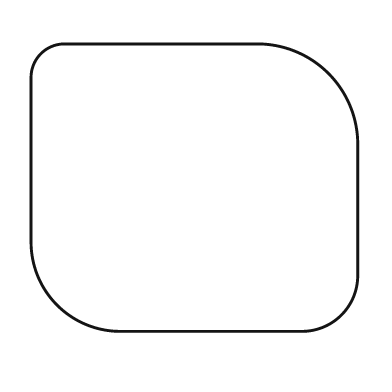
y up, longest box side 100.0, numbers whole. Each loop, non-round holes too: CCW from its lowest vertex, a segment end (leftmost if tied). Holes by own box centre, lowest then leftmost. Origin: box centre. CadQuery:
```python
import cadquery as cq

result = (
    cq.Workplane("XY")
    .moveTo(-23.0, -44.0)
    .lineTo(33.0, -44.0)
    .threePointArc((45.0, -39.0), (50.0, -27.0))
    .lineTo(50.0, 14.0)
    .threePointArc((41.0, 35.0), (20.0, 44.0))
    .lineTo(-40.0, 44.0)
    .threePointArc((-47.0, 41.0), (-50.0, 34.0))
    .lineTo(-50.0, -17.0)
    .threePointArc((-42.0, -36.0), (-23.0, -44.0))
    .close()
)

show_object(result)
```